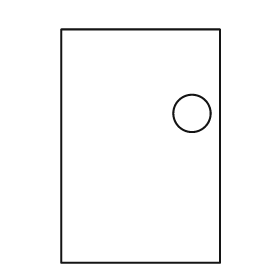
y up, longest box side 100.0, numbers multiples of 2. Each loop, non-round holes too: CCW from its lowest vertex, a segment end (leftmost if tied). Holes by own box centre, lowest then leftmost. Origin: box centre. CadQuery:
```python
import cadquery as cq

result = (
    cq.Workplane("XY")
    .moveTo(-34.0, -50.0)
    .lineTo(34.0, -50.0)
    .lineTo(34.0, 50.0)
    .lineTo(-34.0, 50.0)
    .close()
    .moveTo(22.0, 14.0)
    .circle(8.0)
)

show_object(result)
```